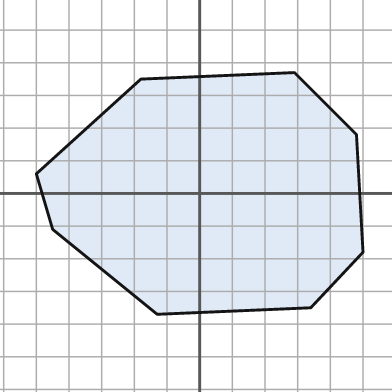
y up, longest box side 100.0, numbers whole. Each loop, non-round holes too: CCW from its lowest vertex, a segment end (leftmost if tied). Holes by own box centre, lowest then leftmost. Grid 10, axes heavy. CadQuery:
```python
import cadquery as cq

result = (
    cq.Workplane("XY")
    .moveTo(-13.0, -37.0)
    .lineTo(34.0, -35.0)
    .lineTo(50.0, -18.0)
    .lineTo(48.0, 18.0)
    .lineTo(29.0, 37.0)
    .lineTo(-18.0, 35.0)
    .lineTo(-50.0, 6.0)
    .lineTo(-45.0, -11.0)
    .close()
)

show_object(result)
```